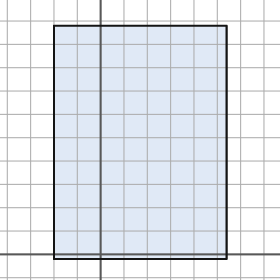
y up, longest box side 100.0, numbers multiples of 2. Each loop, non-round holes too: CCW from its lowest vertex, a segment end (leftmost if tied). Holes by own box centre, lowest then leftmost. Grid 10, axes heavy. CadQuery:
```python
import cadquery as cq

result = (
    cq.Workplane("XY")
    .moveTo(-20.0, -2.0)
    .lineTo(54.0, -2.0)
    .lineTo(54.0, 98.0)
    .lineTo(-20.0, 98.0)
    .close()
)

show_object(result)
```